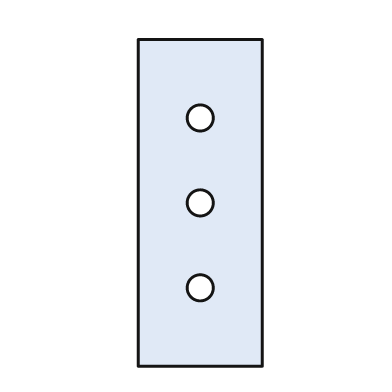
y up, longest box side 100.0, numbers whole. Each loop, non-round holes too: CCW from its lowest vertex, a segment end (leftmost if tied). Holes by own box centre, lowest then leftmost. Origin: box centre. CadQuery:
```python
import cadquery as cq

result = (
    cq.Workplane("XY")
    .moveTo(-19.0, -50.0)
    .lineTo(19.0, -50.0)
    .lineTo(19.0, 50.0)
    .lineTo(-19.0, 50.0)
    .close()
    .moveTo(0.0, -26.0)
    .circle(4.0)
    .moveTo(0.0, 0.0)
    .circle(4.0)
    .moveTo(0.0, 26.0)
    .circle(4.0)
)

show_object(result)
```